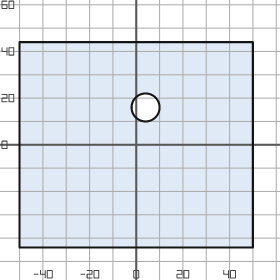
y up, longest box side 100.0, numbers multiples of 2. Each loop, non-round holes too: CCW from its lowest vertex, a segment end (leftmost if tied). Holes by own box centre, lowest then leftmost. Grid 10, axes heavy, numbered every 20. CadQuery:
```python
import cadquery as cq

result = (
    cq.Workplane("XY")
    .moveTo(-50.0, -44.0)
    .lineTo(50.0, -44.0)
    .lineTo(50.0, 44.0)
    .lineTo(-50.0, 44.0)
    .close()
    .moveTo(4.0, 16.0)
    .circle(6.0)
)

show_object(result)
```